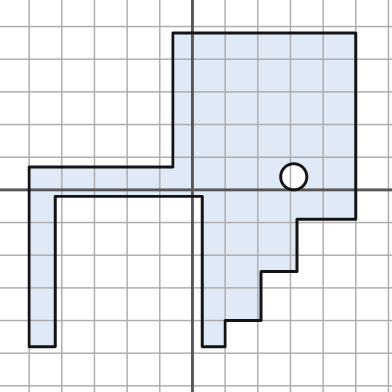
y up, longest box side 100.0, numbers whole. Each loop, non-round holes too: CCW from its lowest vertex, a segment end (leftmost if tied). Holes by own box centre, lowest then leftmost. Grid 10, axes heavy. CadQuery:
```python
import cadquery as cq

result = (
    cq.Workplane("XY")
    .moveTo(-50.0, -48.0)
    .lineTo(-42.0, -48.0)
    .lineTo(-42.0, -2.0)
    .lineTo(3.0, -2.0)
    .lineTo(3.0, -48.0)
    .lineTo(10.0, -48.0)
    .lineTo(10.0, -40.0)
    .lineTo(21.0, -40.0)
    .lineTo(21.0, -25.0)
    .lineTo(32.0, -25.0)
    .lineTo(32.0, -9.0)
    .lineTo(50.0, -9.0)
    .lineTo(50.0, 48.0)
    .lineTo(-6.0, 48.0)
    .lineTo(-6.0, 7.0)
    .lineTo(-50.0, 7.0)
    .close()
    .moveTo(31.0, 4.0)
    .circle(4.0)
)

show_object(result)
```